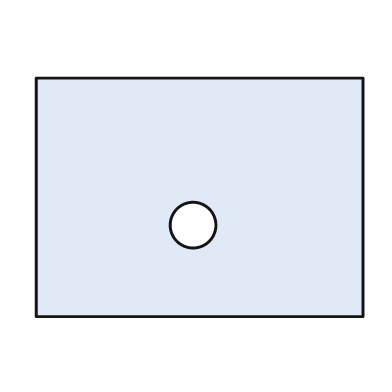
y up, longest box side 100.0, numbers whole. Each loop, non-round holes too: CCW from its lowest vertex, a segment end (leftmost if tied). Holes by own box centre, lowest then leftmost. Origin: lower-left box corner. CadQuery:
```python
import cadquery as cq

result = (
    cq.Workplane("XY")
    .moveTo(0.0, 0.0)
    .lineTo(100.0, 0.0)
    .lineTo(100.0, 73.0)
    .lineTo(0.0, 73.0)
    .close()
    .moveTo(48.0, 28.0)
    .circle(7.0)
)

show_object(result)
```